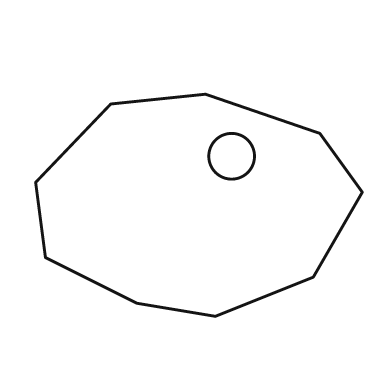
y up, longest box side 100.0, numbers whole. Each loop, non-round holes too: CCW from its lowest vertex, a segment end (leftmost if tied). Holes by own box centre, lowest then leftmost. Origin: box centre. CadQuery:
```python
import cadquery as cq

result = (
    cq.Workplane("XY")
    .moveTo(5.0, -34.0)
    .lineTo(35.0, -22.0)
    .lineTo(50.0, 4.0)
    .lineTo(37.0, 22.0)
    .lineTo(2.0, 34.0)
    .lineTo(-27.0, 31.0)
    .lineTo(-50.0, 7.0)
    .lineTo(-47.0, -16.0)
    .lineTo(-19.0, -30.0)
    .close()
    .moveTo(10.0, 15.0)
    .circle(7.0)
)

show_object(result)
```